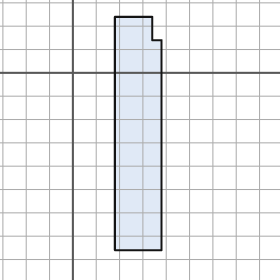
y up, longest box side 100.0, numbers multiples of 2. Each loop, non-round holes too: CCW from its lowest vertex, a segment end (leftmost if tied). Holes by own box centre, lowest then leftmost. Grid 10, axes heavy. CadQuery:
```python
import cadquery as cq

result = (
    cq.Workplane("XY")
    .moveTo(18.0, -76.0)
    .lineTo(38.0, -76.0)
    .lineTo(38.0, 14.0)
    .lineTo(34.0, 14.0)
    .lineTo(34.0, 24.0)
    .lineTo(18.0, 24.0)
    .close()
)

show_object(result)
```